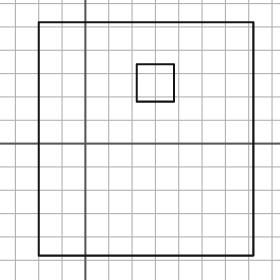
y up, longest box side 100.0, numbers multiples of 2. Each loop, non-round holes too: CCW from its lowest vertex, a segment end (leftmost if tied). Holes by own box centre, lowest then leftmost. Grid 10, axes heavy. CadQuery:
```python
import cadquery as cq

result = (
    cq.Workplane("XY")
    .moveTo(-20.0, -48.0)
    .lineTo(72.0, -48.0)
    .lineTo(72.0, 52.0)
    .lineTo(-20.0, 52.0)
    .close()
    .moveTo(22.0, 18.0)
    .lineTo(38.0, 18.0)
    .lineTo(38.0, 34.0)
    .lineTo(22.0, 34.0)
    .close()
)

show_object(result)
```